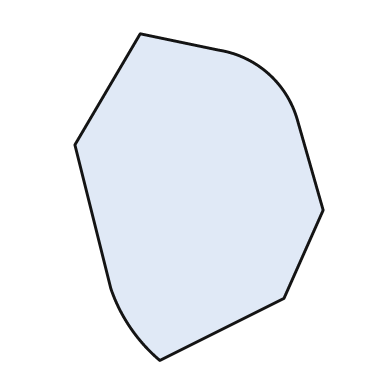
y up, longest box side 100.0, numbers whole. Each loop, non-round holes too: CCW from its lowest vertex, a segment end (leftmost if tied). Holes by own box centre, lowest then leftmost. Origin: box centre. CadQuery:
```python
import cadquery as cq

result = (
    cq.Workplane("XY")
    .moveTo(-12.0, -50.0)
    .lineTo(26.0, -31.0)
    .lineTo(38.0, -4.0)
    .lineTo(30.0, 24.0)
    .threePointArc((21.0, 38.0), (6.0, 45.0))
    .lineTo(-18.0, 50.0)
    .lineTo(-38.0, 16.0)
    .lineTo(-27.0, -28.0)
    .threePointArc((-21.0, -40.0), (-12.0, -50.0))
    .close()
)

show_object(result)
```